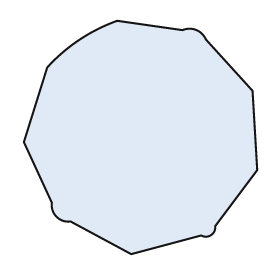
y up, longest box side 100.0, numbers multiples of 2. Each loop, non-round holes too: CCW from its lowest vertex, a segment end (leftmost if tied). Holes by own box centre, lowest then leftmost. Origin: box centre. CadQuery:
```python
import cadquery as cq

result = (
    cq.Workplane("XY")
    .moveTo(-4.0, -50.0)
    .lineTo(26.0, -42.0)
    .threePointArc((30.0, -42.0), (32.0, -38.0))
    .lineTo(50.0, -14.0)
    .lineTo(48.0, 20.0)
    .lineTo(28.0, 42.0)
    .threePointArc((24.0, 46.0), (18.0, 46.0))
    .lineTo(-10.0, 50.0)
    .threePointArc((-26.0, 42.0), (-40.0, 30.0))
    .lineTo(-50.0, -2.0)
    .lineTo(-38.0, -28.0)
    .threePointArc((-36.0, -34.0), (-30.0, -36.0))
    .close()
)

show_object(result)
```